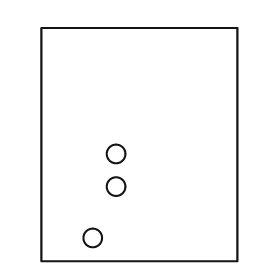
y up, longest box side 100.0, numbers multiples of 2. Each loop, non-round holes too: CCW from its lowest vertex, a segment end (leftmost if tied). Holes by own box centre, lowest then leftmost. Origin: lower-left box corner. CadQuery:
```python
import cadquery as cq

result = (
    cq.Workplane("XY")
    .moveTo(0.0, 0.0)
    .lineTo(84.0, 0.0)
    .lineTo(84.0, 100.0)
    .lineTo(0.0, 100.0)
    .close()
    .moveTo(22.0, 10.0)
    .circle(4.0)
    .moveTo(32.0, 32.0)
    .circle(4.0)
    .moveTo(32.0, 46.0)
    .circle(4.0)
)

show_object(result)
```